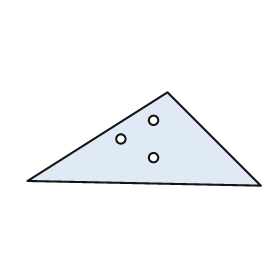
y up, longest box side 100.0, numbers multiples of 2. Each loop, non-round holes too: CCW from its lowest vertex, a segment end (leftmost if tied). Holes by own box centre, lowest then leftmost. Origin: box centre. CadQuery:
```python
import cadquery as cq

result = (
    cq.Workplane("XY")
    .moveTo(50.0, -20.0)
    .lineTo(10.0, 20.0)
    .lineTo(-50.0, -18.0)
    .close()
    .moveTo(4.0, -8.0)
    .circle(2.0)
    .moveTo(-10.0, 0.0)
    .circle(2.0)
    .moveTo(4.0, 8.0)
    .circle(2.0)
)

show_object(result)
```